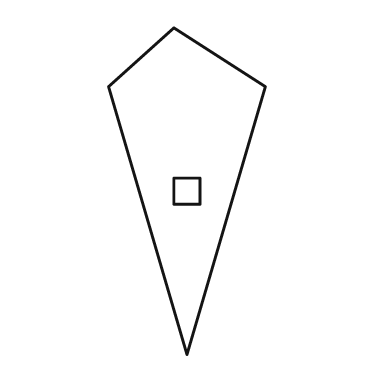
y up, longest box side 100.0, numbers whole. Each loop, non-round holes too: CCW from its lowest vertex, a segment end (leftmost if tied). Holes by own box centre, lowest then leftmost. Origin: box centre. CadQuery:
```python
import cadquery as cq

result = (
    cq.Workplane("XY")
    .moveTo(0.0, -50.0)
    .lineTo(24.0, 32.0)
    .lineTo(-4.0, 50.0)
    .lineTo(-24.0, 32.0)
    .close()
    .moveTo(-4.0, -4.0)
    .lineTo(4.0, -4.0)
    .lineTo(4.0, 4.0)
    .lineTo(-4.0, 4.0)
    .close()
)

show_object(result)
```